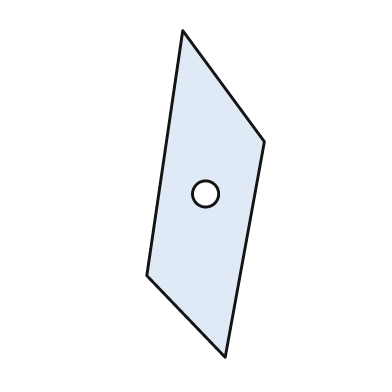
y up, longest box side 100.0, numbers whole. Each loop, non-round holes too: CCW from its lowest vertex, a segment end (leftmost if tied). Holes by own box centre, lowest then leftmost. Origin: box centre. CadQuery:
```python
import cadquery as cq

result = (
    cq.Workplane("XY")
    .moveTo(6.0, -50.0)
    .lineTo(18.0, 16.0)
    .lineTo(-7.0, 50.0)
    .lineTo(-18.0, -25.0)
    .close()
    .moveTo(0.0, 0.0)
    .circle(4.0)
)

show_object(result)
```